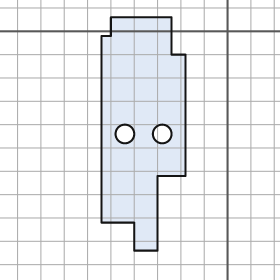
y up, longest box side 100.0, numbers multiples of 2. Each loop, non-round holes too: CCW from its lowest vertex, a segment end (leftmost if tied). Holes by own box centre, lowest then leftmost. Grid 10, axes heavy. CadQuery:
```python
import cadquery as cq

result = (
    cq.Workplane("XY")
    .moveTo(-40.0, -94.0)
    .lineTo(-30.0, -94.0)
    .lineTo(-30.0, -62.0)
    .lineTo(-18.0, -62.0)
    .lineTo(-18.0, -10.0)
    .lineTo(-24.0, -10.0)
    .lineTo(-24.0, 6.0)
    .lineTo(-50.0, 6.0)
    .lineTo(-50.0, -2.0)
    .lineTo(-54.0, -2.0)
    .lineTo(-54.0, -82.0)
    .lineTo(-40.0, -82.0)
    .close()
    .moveTo(-44.0, -44.0)
    .circle(4.0)
    .moveTo(-28.0, -44.0)
    .circle(4.0)
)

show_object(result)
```